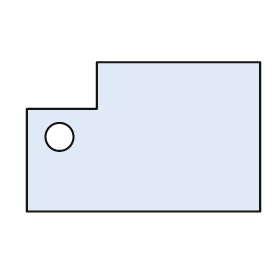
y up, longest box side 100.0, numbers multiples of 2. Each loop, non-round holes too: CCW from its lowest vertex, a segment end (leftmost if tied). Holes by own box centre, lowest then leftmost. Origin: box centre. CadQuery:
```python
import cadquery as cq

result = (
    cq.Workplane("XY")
    .moveTo(-50.0, -32.0)
    .lineTo(50.0, -32.0)
    .lineTo(50.0, 32.0)
    .lineTo(-20.0, 32.0)
    .lineTo(-20.0, 12.0)
    .lineTo(-50.0, 12.0)
    .close()
    .moveTo(-36.0, 0.0)
    .circle(6.0)
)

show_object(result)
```